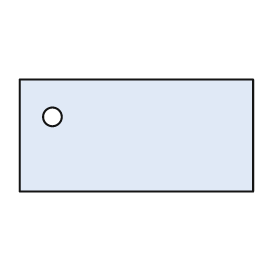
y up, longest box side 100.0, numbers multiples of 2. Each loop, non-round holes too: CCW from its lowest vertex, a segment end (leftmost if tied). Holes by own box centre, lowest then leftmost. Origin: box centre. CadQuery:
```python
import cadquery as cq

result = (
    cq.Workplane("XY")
    .moveTo(-50.0, -24.0)
    .lineTo(50.0, -24.0)
    .lineTo(50.0, 24.0)
    .lineTo(-50.0, 24.0)
    .close()
    .moveTo(-36.0, 8.0)
    .circle(4.0)
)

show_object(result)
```